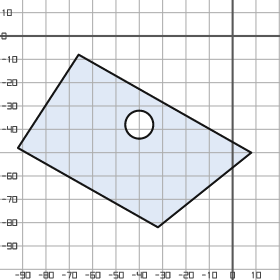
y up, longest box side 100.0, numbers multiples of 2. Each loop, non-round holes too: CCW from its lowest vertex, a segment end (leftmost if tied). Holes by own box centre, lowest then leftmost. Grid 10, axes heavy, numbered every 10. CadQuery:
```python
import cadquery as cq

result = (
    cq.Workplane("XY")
    .moveTo(-32.0, -82.0)
    .lineTo(8.0, -50.0)
    .lineTo(-66.0, -8.0)
    .lineTo(-92.0, -48.0)
    .close()
    .moveTo(-40.0, -38.0)
    .circle(6.0)
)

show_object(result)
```